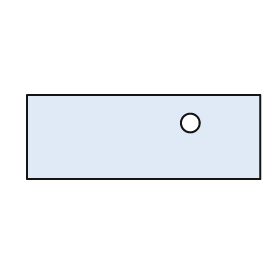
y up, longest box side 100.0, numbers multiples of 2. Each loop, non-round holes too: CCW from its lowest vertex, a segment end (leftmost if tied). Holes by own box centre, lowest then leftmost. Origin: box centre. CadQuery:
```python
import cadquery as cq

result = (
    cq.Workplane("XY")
    .moveTo(-50.0, -18.0)
    .lineTo(50.0, -18.0)
    .lineTo(50.0, 18.0)
    .lineTo(-50.0, 18.0)
    .close()
    .moveTo(20.0, 6.0)
    .circle(4.0)
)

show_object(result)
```